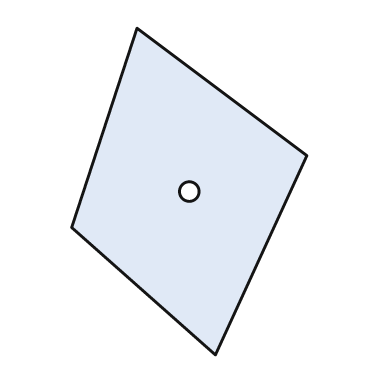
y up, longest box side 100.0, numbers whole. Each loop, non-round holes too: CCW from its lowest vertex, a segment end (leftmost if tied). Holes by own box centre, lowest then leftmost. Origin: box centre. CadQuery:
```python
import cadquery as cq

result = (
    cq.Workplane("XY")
    .moveTo(8.0, -50.0)
    .lineTo(36.0, 11.0)
    .lineTo(-16.0, 50.0)
    .lineTo(-36.0, -11.0)
    .close()
    .moveTo(0.0, 0.0)
    .circle(3.0)
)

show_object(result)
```